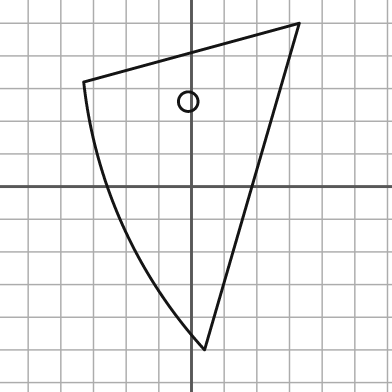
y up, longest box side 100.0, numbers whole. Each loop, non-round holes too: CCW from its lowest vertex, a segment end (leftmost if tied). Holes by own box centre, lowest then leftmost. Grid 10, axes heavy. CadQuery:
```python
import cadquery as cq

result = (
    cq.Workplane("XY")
    .moveTo(4.0, -50.0)
    .lineTo(33.0, 50.0)
    .lineTo(-33.0, 32.0)
    .threePointArc((-21.0, -12.0), (4.0, -50.0))
    .close()
    .moveTo(-1.0, 26.0)
    .circle(3.0)
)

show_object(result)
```